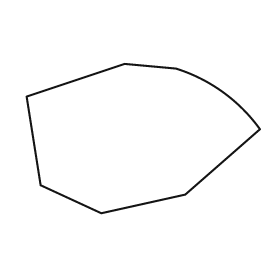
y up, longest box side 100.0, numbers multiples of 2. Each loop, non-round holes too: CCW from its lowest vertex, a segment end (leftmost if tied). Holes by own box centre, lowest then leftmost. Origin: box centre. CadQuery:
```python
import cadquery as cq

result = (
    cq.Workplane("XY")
    .moveTo(-18.0, -32.0)
    .lineTo(18.0, -24.0)
    .lineTo(50.0, 4.0)
    .threePointArc((34.0, 20.0), (14.0, 30.0))
    .lineTo(-8.0, 32.0)
    .lineTo(-50.0, 18.0)
    .lineTo(-44.0, -20.0)
    .close()
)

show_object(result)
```